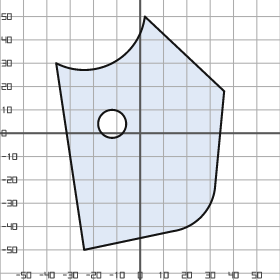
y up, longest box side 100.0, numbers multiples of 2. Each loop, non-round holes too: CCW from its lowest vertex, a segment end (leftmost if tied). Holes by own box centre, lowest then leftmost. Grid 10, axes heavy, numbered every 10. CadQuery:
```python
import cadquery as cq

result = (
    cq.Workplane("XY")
    .moveTo(-24.0, -50.0)
    .lineTo(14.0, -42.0)
    .threePointArc((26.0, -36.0), (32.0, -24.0))
    .lineTo(36.0, 18.0)
    .lineTo(2.0, 50.0)
    .threePointArc((-12.0, 30.0), (-36.0, 30.0))
    .close()
    .moveTo(-12.0, 4.0)
    .circle(6.0)
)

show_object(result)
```